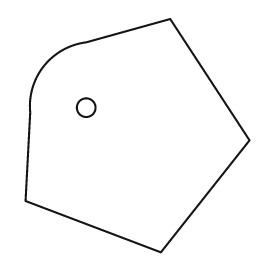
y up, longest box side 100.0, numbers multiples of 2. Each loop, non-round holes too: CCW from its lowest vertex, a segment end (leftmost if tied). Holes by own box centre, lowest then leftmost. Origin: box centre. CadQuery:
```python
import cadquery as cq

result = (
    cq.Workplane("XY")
    .moveTo(10.0, -50.0)
    .lineTo(48.0, -2.0)
    .lineTo(14.0, 50.0)
    .lineTo(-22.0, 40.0)
    .threePointArc((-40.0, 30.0), (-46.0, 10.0))
    .lineTo(-48.0, -28.0)
    .close()
    .moveTo(-22.0, 12.0)
    .circle(4.0)
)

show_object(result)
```